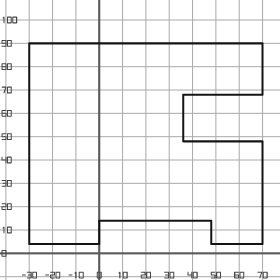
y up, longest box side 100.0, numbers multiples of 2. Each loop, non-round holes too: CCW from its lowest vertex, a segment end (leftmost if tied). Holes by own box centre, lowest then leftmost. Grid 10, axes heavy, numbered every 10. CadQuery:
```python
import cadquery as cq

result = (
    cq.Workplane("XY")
    .moveTo(-30.0, 4.0)
    .lineTo(0.0, 4.0)
    .lineTo(0.0, 14.0)
    .lineTo(48.0, 14.0)
    .lineTo(48.0, 4.0)
    .lineTo(70.0, 4.0)
    .lineTo(70.0, 48.0)
    .lineTo(36.0, 48.0)
    .lineTo(36.0, 68.0)
    .lineTo(70.0, 68.0)
    .lineTo(70.0, 90.0)
    .lineTo(-30.0, 90.0)
    .close()
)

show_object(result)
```